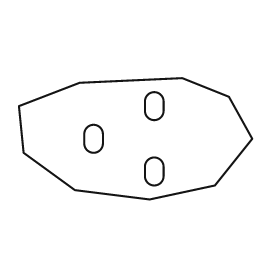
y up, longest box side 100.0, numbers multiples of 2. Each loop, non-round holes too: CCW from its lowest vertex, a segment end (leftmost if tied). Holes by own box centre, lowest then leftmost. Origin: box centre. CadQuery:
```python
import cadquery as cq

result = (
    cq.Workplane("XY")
    .moveTo(6.0, -26.0)
    .lineTo(34.0, -20.0)
    .lineTo(50.0, 0.0)
    .lineTo(40.0, 18.0)
    .lineTo(20.0, 26.0)
    .lineTo(-24.0, 24.0)
    .lineTo(-50.0, 14.0)
    .lineTo(-48.0, -6.0)
    .lineTo(-26.0, -22.0)
    .close()
    .moveTo(4.0, -16.0)
    .threePointArc((8.0, -20.0), (12.0, -16.0))
    .lineTo(12.0, -12.0)
    .threePointArc((8.0, -8.0), (4.0, -12.0))
    .close()
    .moveTo(-22.0, -2.0)
    .threePointArc((-18.0, -6.0), (-14.0, -2.0))
    .lineTo(-14.0, 2.0)
    .threePointArc((-18.0, 6.0), (-22.0, 2.0))
    .close()
    .moveTo(4.0, 12.0)
    .threePointArc((8.0, 8.0), (12.0, 12.0))
    .lineTo(12.0, 16.0)
    .threePointArc((8.0, 20.0), (4.0, 16.0))
    .close()
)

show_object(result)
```